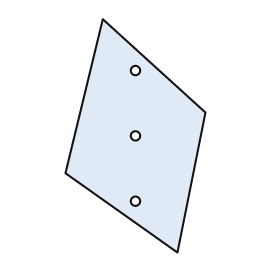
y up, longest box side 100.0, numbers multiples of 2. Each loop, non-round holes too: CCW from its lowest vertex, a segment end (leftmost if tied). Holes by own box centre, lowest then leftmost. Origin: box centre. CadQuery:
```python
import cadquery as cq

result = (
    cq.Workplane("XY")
    .moveTo(18.0, -50.0)
    .lineTo(30.0, 10.0)
    .lineTo(-14.0, 50.0)
    .lineTo(-30.0, -16.0)
    .close()
    .moveTo(0.0, -28.0)
    .circle(2.0)
    .moveTo(0.0, 0.0)
    .circle(2.0)
    .moveTo(0.0, 28.0)
    .circle(2.0)
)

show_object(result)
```